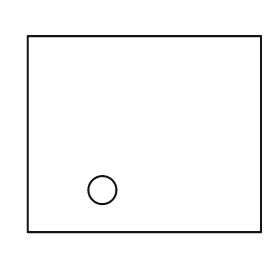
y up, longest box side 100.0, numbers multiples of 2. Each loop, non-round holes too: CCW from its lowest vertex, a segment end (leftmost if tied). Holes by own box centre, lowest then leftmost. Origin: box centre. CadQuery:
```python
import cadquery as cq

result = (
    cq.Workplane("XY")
    .moveTo(-50.0, -42.0)
    .lineTo(50.0, -42.0)
    .lineTo(50.0, 42.0)
    .lineTo(-50.0, 42.0)
    .close()
    .moveTo(-18.0, -24.0)
    .circle(6.0)
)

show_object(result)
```